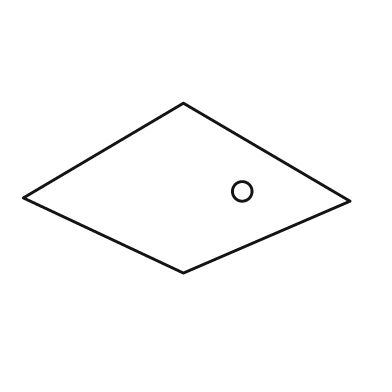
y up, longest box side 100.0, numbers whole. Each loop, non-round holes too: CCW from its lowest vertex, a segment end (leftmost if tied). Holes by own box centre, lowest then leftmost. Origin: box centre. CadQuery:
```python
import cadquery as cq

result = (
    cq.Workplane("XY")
    .moveTo(-1.0, -26.0)
    .lineTo(50.0, -4.0)
    .lineTo(-1.0, 26.0)
    .lineTo(-50.0, -3.0)
    .close()
    .moveTo(17.0, -1.0)
    .circle(3.0)
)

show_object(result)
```